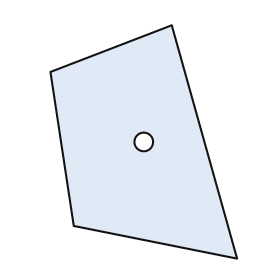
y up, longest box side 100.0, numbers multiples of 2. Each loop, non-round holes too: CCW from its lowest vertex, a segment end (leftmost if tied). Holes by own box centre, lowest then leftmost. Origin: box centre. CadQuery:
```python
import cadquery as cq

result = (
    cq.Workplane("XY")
    .moveTo(40.0, -50.0)
    .lineTo(12.0, 50.0)
    .lineTo(-40.0, 30.0)
    .lineTo(-30.0, -36.0)
    .close()
    .moveTo(0.0, 0.0)
    .circle(4.0)
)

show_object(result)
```